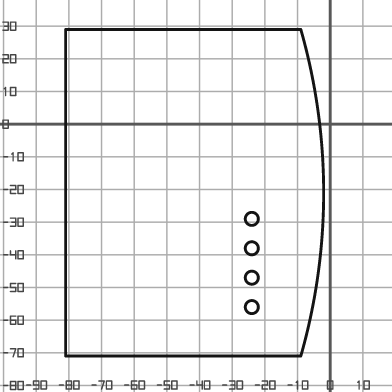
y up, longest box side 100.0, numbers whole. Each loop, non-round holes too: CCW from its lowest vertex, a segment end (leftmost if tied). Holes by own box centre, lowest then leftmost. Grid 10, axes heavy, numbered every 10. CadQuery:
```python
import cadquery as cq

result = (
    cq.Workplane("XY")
    .moveTo(-81.0, -71.0)
    .lineTo(-9.0, -71.0)
    .threePointArc((-2.0, -21.0), (-9.0, 29.0))
    .lineTo(-81.0, 29.0)
    .close()
    .moveTo(-24.0, -56.0)
    .circle(2.0)
    .moveTo(-24.0, -47.0)
    .circle(2.0)
    .moveTo(-24.0, -38.0)
    .circle(2.0)
    .moveTo(-24.0, -29.0)
    .circle(2.0)
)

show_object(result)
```